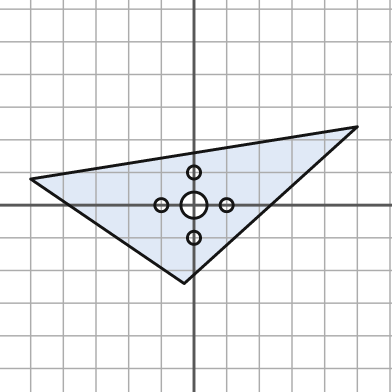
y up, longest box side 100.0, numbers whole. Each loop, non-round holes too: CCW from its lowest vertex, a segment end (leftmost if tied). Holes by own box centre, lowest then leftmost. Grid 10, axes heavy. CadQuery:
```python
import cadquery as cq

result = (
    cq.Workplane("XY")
    .moveTo(-3.0, -24.0)
    .lineTo(50.0, 24.0)
    .lineTo(-50.0, 8.0)
    .close()
    .moveTo(0.0, -10.0)
    .circle(2.0)
    .moveTo(-10.0, 0.0)
    .circle(2.0)
    .moveTo(0.0, 0.0)
    .circle(4.0)
    .moveTo(10.0, 0.0)
    .circle(2.0)
    .moveTo(0.0, 10.0)
    .circle(2.0)
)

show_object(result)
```